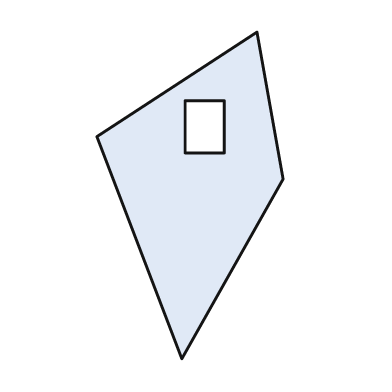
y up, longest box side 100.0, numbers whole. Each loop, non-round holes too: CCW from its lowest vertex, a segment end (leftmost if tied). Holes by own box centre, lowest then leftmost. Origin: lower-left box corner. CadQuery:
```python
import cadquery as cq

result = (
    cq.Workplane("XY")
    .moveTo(26.0, 0.0)
    .lineTo(57.0, 55.0)
    .lineTo(49.0, 100.0)
    .lineTo(0.0, 68.0)
    .close()
    .moveTo(27.0, 63.0)
    .lineTo(39.0, 63.0)
    .lineTo(39.0, 79.0)
    .lineTo(27.0, 79.0)
    .close()
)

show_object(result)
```